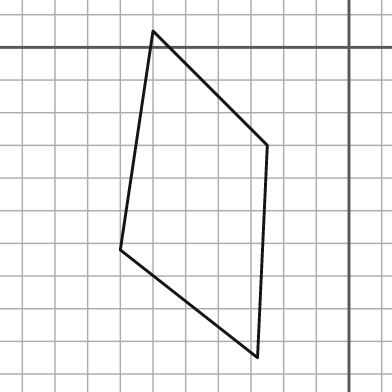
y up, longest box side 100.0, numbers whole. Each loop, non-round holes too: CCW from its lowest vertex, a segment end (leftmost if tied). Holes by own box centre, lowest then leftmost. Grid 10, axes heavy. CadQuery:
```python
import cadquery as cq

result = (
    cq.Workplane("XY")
    .moveTo(-28.0, -95.0)
    .lineTo(-25.0, -30.0)
    .lineTo(-60.0, 5.0)
    .lineTo(-70.0, -62.0)
    .close()
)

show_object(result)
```